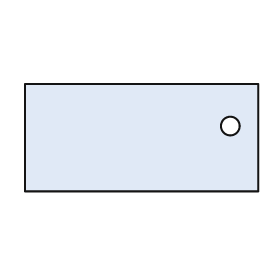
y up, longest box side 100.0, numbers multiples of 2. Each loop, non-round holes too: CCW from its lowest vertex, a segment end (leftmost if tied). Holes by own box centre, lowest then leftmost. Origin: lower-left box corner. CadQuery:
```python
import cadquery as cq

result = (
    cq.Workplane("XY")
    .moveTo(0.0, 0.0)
    .lineTo(100.0, 0.0)
    .lineTo(100.0, 46.0)
    .lineTo(0.0, 46.0)
    .close()
    .moveTo(88.0, 28.0)
    .circle(4.0)
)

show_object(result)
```